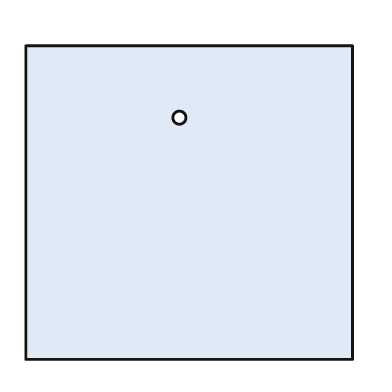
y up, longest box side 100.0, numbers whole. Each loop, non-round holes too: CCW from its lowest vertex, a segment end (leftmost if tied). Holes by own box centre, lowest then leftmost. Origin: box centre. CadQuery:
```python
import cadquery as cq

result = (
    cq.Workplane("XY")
    .moveTo(-50.0, -48.0)
    .lineTo(50.0, -48.0)
    .lineTo(50.0, 48.0)
    .lineTo(-50.0, 48.0)
    .close()
    .moveTo(-3.0, 26.0)
    .circle(2.0)
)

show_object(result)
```